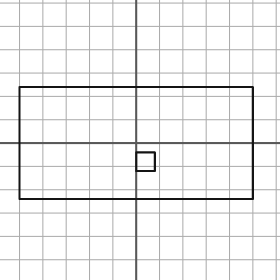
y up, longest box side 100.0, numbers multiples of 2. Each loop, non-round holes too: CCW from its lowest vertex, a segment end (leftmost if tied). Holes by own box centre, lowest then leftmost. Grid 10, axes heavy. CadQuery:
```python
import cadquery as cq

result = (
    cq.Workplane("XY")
    .moveTo(-50.0, -24.0)
    .lineTo(50.0, -24.0)
    .lineTo(50.0, 24.0)
    .lineTo(-50.0, 24.0)
    .close()
    .moveTo(0.0, -12.0)
    .lineTo(8.0, -12.0)
    .lineTo(8.0, -4.0)
    .lineTo(0.0, -4.0)
    .close()
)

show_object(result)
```